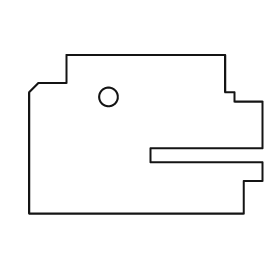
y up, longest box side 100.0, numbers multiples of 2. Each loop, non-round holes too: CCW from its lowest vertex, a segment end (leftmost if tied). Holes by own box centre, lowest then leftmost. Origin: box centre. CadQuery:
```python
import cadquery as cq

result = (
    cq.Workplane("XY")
    .moveTo(-50.0, -34.0)
    .lineTo(42.0, -34.0)
    .lineTo(42.0, -20.0)
    .lineTo(50.0, -20.0)
    .lineTo(50.0, -12.0)
    .lineTo(2.0, -12.0)
    .lineTo(2.0, -6.0)
    .lineTo(50.0, -6.0)
    .lineTo(50.0, 14.0)
    .lineTo(38.0, 14.0)
    .lineTo(38.0, 18.0)
    .lineTo(34.0, 18.0)
    .lineTo(34.0, 34.0)
    .lineTo(-34.0, 34.0)
    .lineTo(-34.0, 22.0)
    .lineTo(-46.0, 22.0)
    .lineTo(-50.0, 18.0)
    .close()
    .moveTo(-16.0, 16.0)
    .circle(4.0)
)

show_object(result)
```